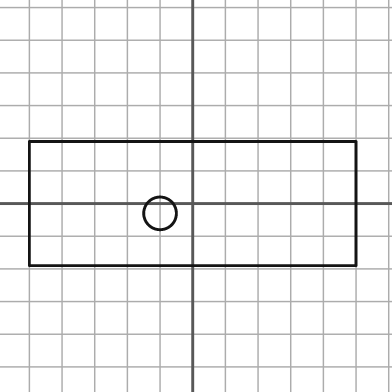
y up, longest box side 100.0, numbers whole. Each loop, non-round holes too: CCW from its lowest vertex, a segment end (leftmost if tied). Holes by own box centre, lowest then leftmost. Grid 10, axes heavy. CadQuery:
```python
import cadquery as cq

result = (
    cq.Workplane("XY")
    .moveTo(-50.0, -19.0)
    .lineTo(50.0, -19.0)
    .lineTo(50.0, 19.0)
    .lineTo(-50.0, 19.0)
    .close()
    .moveTo(-10.0, -3.0)
    .circle(5.0)
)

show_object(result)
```